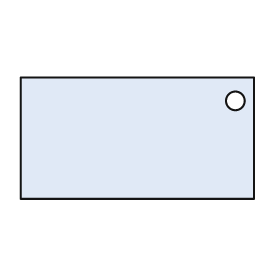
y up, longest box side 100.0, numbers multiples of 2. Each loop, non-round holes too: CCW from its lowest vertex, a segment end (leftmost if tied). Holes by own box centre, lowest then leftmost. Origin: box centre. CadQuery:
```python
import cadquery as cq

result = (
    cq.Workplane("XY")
    .moveTo(-50.0, -26.0)
    .lineTo(50.0, -26.0)
    .lineTo(50.0, 26.0)
    .lineTo(-50.0, 26.0)
    .close()
    .moveTo(42.0, 16.0)
    .circle(4.0)
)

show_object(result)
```